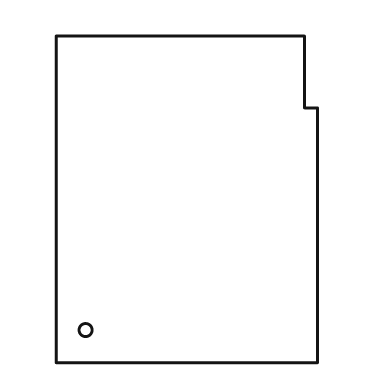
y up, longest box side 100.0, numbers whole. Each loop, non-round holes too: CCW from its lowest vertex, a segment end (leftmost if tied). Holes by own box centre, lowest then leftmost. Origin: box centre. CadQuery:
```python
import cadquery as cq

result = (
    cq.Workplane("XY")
    .moveTo(-40.0, -50.0)
    .lineTo(40.0, -50.0)
    .lineTo(40.0, 28.0)
    .lineTo(36.0, 28.0)
    .lineTo(36.0, 50.0)
    .lineTo(-40.0, 50.0)
    .close()
    .moveTo(-31.0, -40.0)
    .circle(2.0)
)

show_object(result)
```